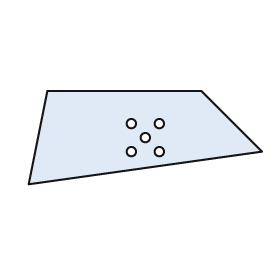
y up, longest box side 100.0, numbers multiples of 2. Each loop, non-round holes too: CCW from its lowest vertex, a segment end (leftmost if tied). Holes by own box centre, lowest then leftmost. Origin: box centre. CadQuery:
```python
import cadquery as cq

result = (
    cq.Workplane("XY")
    .moveTo(-50.0, -20.0)
    .lineTo(50.0, -6.0)
    .lineTo(24.0, 20.0)
    .lineTo(-42.0, 20.0)
    .close()
    .moveTo(-6.0, -6.0)
    .circle(2.0)
    .moveTo(6.0, -6.0)
    .circle(2.0)
    .moveTo(0.0, 0.0)
    .circle(2.0)
    .moveTo(-6.0, 6.0)
    .circle(2.0)
    .moveTo(6.0, 6.0)
    .circle(2.0)
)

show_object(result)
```